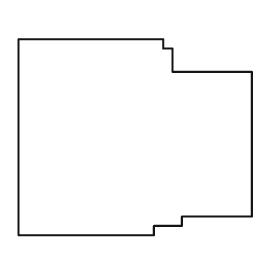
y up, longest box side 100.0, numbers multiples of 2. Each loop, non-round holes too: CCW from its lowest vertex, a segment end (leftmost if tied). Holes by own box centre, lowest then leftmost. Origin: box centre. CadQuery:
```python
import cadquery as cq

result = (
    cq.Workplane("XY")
    .moveTo(-50.0, -42.0)
    .lineTo(8.0, -42.0)
    .lineTo(8.0, -38.0)
    .lineTo(20.0, -38.0)
    .lineTo(20.0, -34.0)
    .lineTo(50.0, -34.0)
    .lineTo(50.0, 28.0)
    .lineTo(16.0, 28.0)
    .lineTo(16.0, 38.0)
    .lineTo(12.0, 38.0)
    .lineTo(12.0, 42.0)
    .lineTo(-50.0, 42.0)
    .close()
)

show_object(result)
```